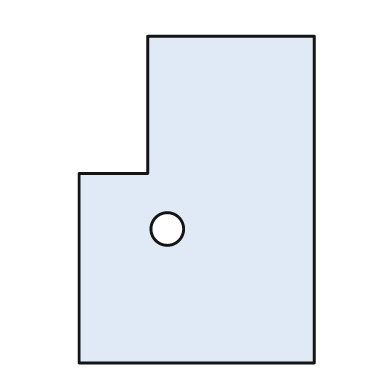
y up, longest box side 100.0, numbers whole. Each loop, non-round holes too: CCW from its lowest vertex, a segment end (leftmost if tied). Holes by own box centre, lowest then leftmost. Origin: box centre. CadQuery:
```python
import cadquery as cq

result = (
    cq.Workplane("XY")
    .moveTo(-36.0, -50.0)
    .lineTo(36.0, -50.0)
    .lineTo(36.0, 50.0)
    .lineTo(-15.0, 50.0)
    .lineTo(-15.0, 8.0)
    .lineTo(-36.0, 8.0)
    .close()
    .moveTo(-9.0, -9.0)
    .circle(5.0)
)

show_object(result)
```